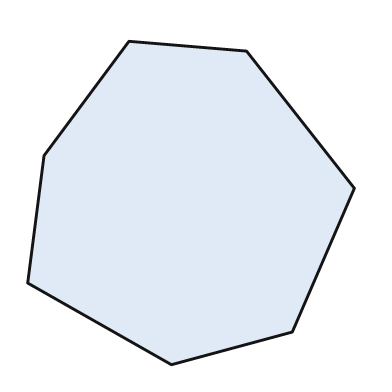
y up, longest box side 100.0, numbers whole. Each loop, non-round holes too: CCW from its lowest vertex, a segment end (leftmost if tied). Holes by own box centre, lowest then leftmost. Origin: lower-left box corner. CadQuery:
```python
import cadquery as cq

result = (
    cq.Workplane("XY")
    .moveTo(44.0, 0.0)
    .lineTo(81.0, 10.0)
    .lineTo(100.0, 54.0)
    .lineTo(67.0, 96.0)
    .lineTo(31.0, 99.0)
    .lineTo(5.0, 64.0)
    .lineTo(0.0, 25.0)
    .close()
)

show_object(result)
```